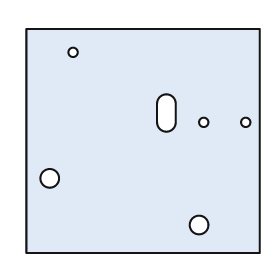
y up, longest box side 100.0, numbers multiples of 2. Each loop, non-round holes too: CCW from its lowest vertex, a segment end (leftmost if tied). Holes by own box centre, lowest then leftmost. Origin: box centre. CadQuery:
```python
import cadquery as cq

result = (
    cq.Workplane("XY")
    .moveTo(-50.0, -48.0)
    .lineTo(50.0, -48.0)
    .lineTo(50.0, 48.0)
    .lineTo(-50.0, 48.0)
    .close()
    .moveTo(24.0, -36.0)
    .circle(4.0)
    .moveTo(-40.0, -16.0)
    .circle(4.0)
    .moveTo(26.0, 8.0)
    .circle(2.0)
    .moveTo(44.0, 8.0)
    .circle(2.0)
    .moveTo(6.0, 8.0)
    .threePointArc((10.0, 4.0), (14.0, 8.0))
    .lineTo(14.0, 16.0)
    .threePointArc((10.0, 20.0), (6.0, 16.0))
    .close()
    .moveTo(-30.0, 38.0)
    .circle(2.0)
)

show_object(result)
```